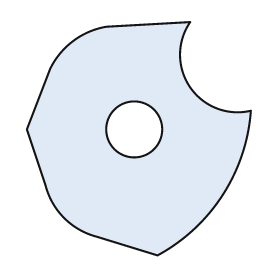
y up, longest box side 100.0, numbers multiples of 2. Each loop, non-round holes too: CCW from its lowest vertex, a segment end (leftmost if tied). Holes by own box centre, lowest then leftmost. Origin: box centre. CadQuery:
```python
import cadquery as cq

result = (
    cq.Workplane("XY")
    .moveTo(8.0, -50.0)
    .threePointArc((36.0, -24.0), (48.0, 12.0))
    .threePointArc((22.0, 22.0), (22.0, 50.0))
    .lineTo(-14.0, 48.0)
    .threePointArc((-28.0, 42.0), (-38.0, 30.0))
    .lineTo(-48.0, 4.0)
    .lineTo(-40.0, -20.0)
    .threePointArc((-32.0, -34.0), (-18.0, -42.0))
    .close()
    .moveTo(-2.0, 4.0)
    .circle(12.0)
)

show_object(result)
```